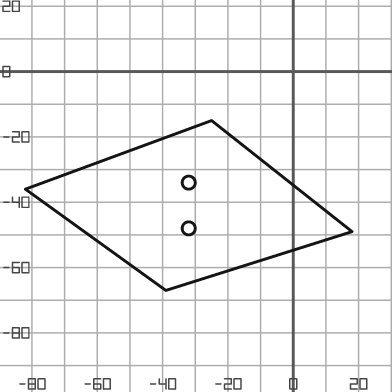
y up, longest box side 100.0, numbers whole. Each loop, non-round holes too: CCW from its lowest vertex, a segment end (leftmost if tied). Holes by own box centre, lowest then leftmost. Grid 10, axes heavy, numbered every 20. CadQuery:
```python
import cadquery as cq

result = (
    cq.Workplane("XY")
    .moveTo(-39.0, -67.0)
    .lineTo(18.0, -49.0)
    .lineTo(-25.0, -15.0)
    .lineTo(-82.0, -36.0)
    .close()
    .moveTo(-32.0, -48.0)
    .circle(2.0)
    .moveTo(-32.0, -34.0)
    .circle(2.0)
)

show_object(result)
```